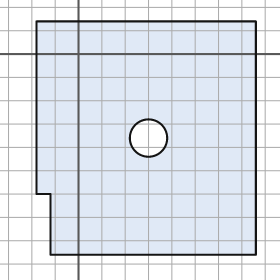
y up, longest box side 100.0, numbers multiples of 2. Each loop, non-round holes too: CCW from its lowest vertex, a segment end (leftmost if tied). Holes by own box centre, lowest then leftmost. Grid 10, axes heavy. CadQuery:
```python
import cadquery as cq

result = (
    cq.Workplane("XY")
    .moveTo(-12.0, -86.0)
    .lineTo(76.0, -86.0)
    .lineTo(76.0, 14.0)
    .lineTo(-18.0, 14.0)
    .lineTo(-18.0, -60.0)
    .lineTo(-12.0, -60.0)
    .close()
    .moveTo(30.0, -36.0)
    .circle(8.0)
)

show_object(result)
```